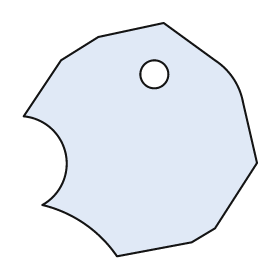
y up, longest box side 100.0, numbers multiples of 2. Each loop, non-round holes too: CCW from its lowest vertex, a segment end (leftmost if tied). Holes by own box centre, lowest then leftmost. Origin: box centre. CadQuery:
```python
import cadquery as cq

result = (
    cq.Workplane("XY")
    .moveTo(-10.0, -50.0)
    .lineTo(22.0, -44.0)
    .lineTo(32.0, -38.0)
    .lineTo(50.0, -10.0)
    .lineTo(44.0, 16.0)
    .threePointArc((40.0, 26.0), (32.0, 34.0))
    .lineTo(10.0, 50.0)
    .lineTo(-18.0, 44.0)
    .lineTo(-34.0, 34.0)
    .lineTo(-50.0, 10.0)
    .threePointArc((-32.0, -6.0), (-42.0, -28.0))
    .threePointArc((-24.0, -36.0), (-10.0, -50.0))
    .close()
    .moveTo(6.0, 28.0)
    .circle(6.0)
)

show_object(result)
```